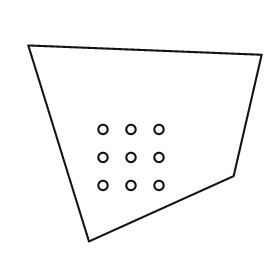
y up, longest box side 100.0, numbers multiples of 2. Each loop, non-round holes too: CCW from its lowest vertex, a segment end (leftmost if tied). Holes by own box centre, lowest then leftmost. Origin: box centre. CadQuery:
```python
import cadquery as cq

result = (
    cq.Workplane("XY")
    .moveTo(-24.0, -42.0)
    .lineTo(38.0, -14.0)
    .lineTo(50.0, 38.0)
    .lineTo(-50.0, 42.0)
    .close()
    .moveTo(-18.0, -18.0)
    .circle(2.0)
    .moveTo(-6.0, -18.0)
    .circle(2.0)
    .moveTo(6.0, -18.0)
    .circle(2.0)
    .moveTo(-18.0, -6.0)
    .circle(2.0)
    .moveTo(-6.0, -6.0)
    .circle(2.0)
    .moveTo(6.0, -6.0)
    .circle(2.0)
    .moveTo(-18.0, 6.0)
    .circle(2.0)
    .moveTo(-6.0, 6.0)
    .circle(2.0)
    .moveTo(6.0, 6.0)
    .circle(2.0)
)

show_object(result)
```